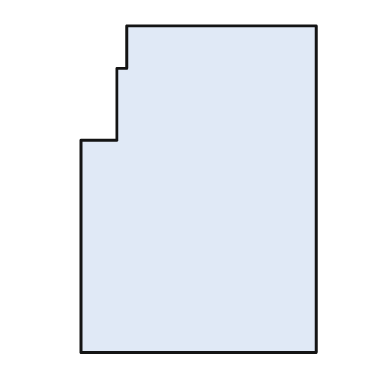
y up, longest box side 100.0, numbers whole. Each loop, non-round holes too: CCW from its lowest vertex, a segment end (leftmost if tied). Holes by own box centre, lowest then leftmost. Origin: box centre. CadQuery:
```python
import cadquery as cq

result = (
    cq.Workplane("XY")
    .moveTo(-36.0, -50.0)
    .lineTo(36.0, -50.0)
    .lineTo(36.0, 50.0)
    .lineTo(-22.0, 50.0)
    .lineTo(-22.0, 37.0)
    .lineTo(-25.0, 37.0)
    .lineTo(-25.0, 15.0)
    .lineTo(-36.0, 15.0)
    .close()
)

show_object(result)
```